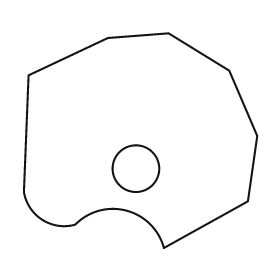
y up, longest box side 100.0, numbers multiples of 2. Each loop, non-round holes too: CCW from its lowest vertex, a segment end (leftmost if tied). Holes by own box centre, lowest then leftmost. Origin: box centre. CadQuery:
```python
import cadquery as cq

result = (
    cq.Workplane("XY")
    .moveTo(10.0, -46.0)
    .lineTo(46.0, -26.0)
    .lineTo(50.0, 2.0)
    .lineTo(38.0, 30.0)
    .lineTo(12.0, 46.0)
    .lineTo(-14.0, 44.0)
    .lineTo(-48.0, 28.0)
    .lineTo(-50.0, -22.0)
    .threePointArc((-42.0, -34.0), (-28.0, -36.0))
    .threePointArc((-6.0, -30.0), (10.0, -46.0))
    .close()
    .moveTo(-2.0, -12.0)
    .circle(10.0)
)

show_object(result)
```